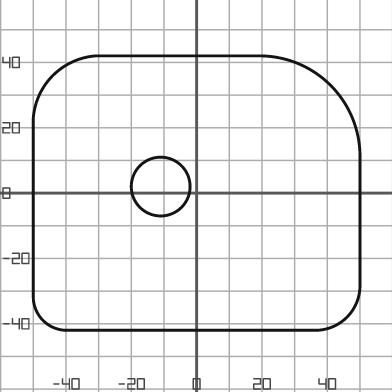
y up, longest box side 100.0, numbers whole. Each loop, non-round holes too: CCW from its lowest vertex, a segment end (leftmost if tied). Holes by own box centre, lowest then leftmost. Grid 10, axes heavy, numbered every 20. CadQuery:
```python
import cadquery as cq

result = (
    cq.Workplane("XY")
    .moveTo(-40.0, -42.0)
    .lineTo(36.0, -42.0)
    .threePointArc((46.0, -38.0), (50.0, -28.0))
    .lineTo(50.0, 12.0)
    .threePointArc((41.0, 33.0), (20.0, 42.0))
    .lineTo(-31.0, 42.0)
    .threePointArc((-44.0, 36.0), (-50.0, 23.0))
    .lineTo(-50.0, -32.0)
    .threePointArc((-47.0, -39.0), (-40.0, -42.0))
    .close()
    .moveTo(-11.0, 2.0)
    .circle(9.0)
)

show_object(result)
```